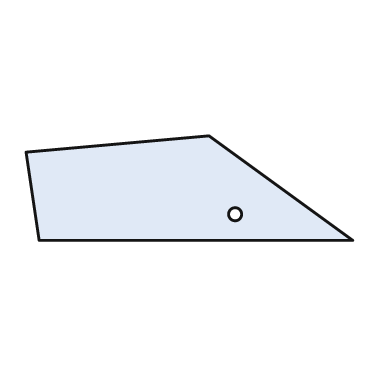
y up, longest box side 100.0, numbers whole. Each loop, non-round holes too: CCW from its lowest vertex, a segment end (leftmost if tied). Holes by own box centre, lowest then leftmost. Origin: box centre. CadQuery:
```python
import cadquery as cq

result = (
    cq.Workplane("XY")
    .moveTo(-46.0, -16.0)
    .lineTo(50.0, -16.0)
    .lineTo(6.0, 16.0)
    .lineTo(-50.0, 11.0)
    .close()
    .moveTo(14.0, -8.0)
    .circle(2.0)
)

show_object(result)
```